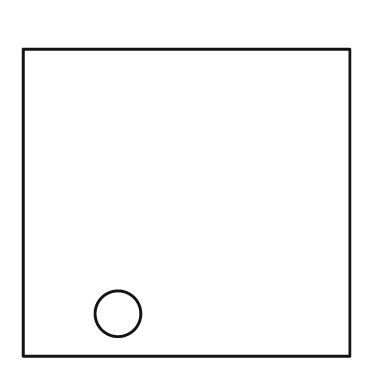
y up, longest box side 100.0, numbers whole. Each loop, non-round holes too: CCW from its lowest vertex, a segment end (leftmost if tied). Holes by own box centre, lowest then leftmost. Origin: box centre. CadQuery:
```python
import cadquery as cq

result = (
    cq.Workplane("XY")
    .moveTo(-50.0, -47.0)
    .lineTo(50.0, -47.0)
    .lineTo(50.0, 47.0)
    .lineTo(-50.0, 47.0)
    .close()
    .moveTo(-21.0, -34.0)
    .circle(7.0)
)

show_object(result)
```